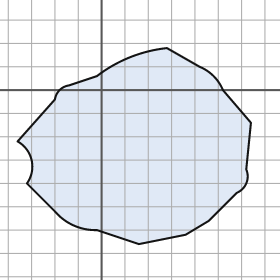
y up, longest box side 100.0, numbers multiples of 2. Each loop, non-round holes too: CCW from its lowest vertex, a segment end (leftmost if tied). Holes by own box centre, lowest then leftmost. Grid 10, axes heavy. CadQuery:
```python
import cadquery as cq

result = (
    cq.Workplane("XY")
    .moveTo(16.0, -66.0)
    .lineTo(36.0, -62.0)
    .lineTo(46.0, -56.0)
    .lineTo(58.0, -44.0)
    .threePointArc((62.0, -40.0), (62.0, -34.0))
    .lineTo(64.0, -14.0)
    .lineTo(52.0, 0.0)
    .threePointArc((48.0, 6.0), (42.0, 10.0))
    .lineTo(28.0, 18.0)
    .threePointArc((12.0, 14.0), (-2.0, 6.0))
    .lineTo(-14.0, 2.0)
    .threePointArc((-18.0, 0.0), (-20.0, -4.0))
    .lineTo(-36.0, -22.0)
    .threePointArc((-30.0, -30.0), (-32.0, -40.0))
    .lineTo(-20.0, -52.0)
    .threePointArc((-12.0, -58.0), (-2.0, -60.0))
    .close()
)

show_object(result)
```